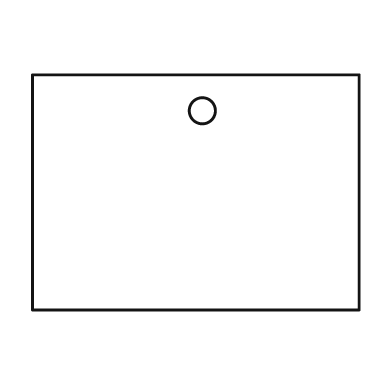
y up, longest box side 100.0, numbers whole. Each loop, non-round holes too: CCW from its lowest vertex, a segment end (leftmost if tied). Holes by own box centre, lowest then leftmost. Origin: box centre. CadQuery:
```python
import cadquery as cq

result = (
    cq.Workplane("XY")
    .moveTo(-50.0, -36.0)
    .lineTo(50.0, -36.0)
    .lineTo(50.0, 36.0)
    .lineTo(-50.0, 36.0)
    .close()
    .moveTo(2.0, 25.0)
    .circle(4.0)
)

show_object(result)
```